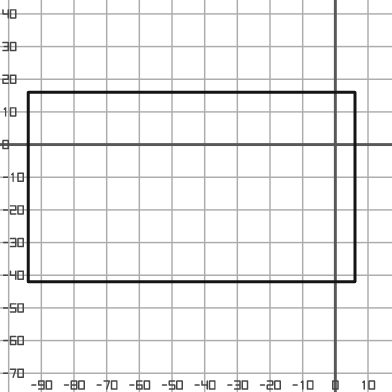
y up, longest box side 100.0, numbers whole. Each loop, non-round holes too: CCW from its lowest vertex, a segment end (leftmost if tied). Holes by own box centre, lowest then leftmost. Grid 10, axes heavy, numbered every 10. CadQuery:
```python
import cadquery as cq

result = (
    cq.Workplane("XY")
    .moveTo(-94.0, -42.0)
    .lineTo(6.0, -42.0)
    .lineTo(6.0, 16.0)
    .lineTo(-94.0, 16.0)
    .close()
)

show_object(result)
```